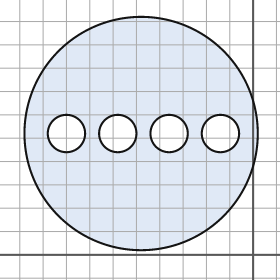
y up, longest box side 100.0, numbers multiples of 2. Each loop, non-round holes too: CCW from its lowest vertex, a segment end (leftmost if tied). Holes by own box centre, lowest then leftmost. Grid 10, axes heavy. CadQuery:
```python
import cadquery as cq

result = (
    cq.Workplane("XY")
    .moveTo(-48.0, 52.0)
    .circle(50.0)
    .moveTo(-80.0, 52.0)
    .circle(8.0)
    .moveTo(-58.0, 52.0)
    .circle(8.0)
    .moveTo(-36.0, 52.0)
    .circle(8.0)
    .moveTo(-14.0, 52.0)
    .circle(8.0)
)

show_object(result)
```